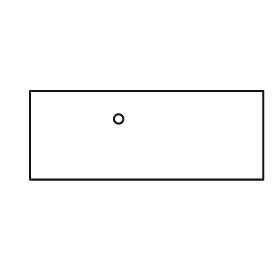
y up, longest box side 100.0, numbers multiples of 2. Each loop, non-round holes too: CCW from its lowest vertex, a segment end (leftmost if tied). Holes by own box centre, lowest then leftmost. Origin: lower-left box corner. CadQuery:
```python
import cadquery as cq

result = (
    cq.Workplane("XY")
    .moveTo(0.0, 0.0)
    .lineTo(100.0, 0.0)
    .lineTo(100.0, 38.0)
    .lineTo(0.0, 38.0)
    .close()
    .moveTo(38.0, 26.0)
    .circle(2.0)
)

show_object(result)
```